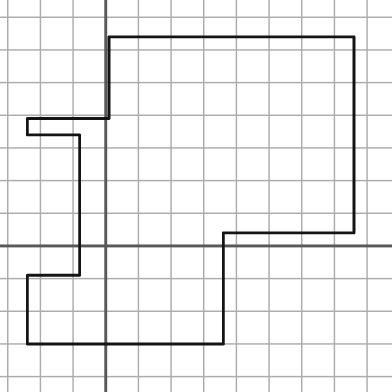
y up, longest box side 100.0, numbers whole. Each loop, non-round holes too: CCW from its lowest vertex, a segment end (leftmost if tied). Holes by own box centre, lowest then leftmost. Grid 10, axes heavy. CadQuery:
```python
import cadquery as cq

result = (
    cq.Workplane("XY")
    .moveTo(-24.0, -30.0)
    .lineTo(36.0, -30.0)
    .lineTo(36.0, 4.0)
    .lineTo(76.0, 4.0)
    .lineTo(76.0, 64.0)
    .lineTo(1.0, 64.0)
    .lineTo(1.0, 39.0)
    .lineTo(-24.0, 39.0)
    .lineTo(-24.0, 34.0)
    .lineTo(-8.0, 34.0)
    .lineTo(-8.0, -9.0)
    .lineTo(-24.0, -9.0)
    .close()
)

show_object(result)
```